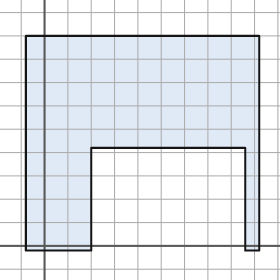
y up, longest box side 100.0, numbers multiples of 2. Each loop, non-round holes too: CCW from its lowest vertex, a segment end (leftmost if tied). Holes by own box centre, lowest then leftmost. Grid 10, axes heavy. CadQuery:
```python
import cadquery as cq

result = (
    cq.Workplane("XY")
    .moveTo(-8.0, -2.0)
    .lineTo(20.0, -2.0)
    .lineTo(20.0, 42.0)
    .lineTo(86.0, 42.0)
    .lineTo(86.0, -2.0)
    .lineTo(92.0, -2.0)
    .lineTo(92.0, 90.0)
    .lineTo(-8.0, 90.0)
    .close()
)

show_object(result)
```